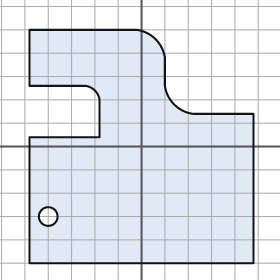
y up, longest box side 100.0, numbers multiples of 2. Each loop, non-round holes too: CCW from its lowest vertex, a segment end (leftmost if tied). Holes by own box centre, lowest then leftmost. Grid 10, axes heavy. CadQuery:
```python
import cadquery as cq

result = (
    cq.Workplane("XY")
    .moveTo(-48.0, -50.0)
    .lineTo(48.0, -50.0)
    .lineTo(48.0, 14.0)
    .lineTo(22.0, 14.0)
    .threePointArc((14.0, 18.0), (10.0, 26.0))
    .lineTo(10.0, 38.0)
    .threePointArc((6.0, 46.0), (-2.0, 50.0))
    .lineTo(-48.0, 50.0)
    .lineTo(-48.0, 26.0)
    .lineTo(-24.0, 26.0)
    .threePointArc((-20.0, 24.0), (-18.0, 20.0))
    .lineTo(-18.0, 4.0)
    .lineTo(-48.0, 4.0)
    .close()
    .moveTo(-40.0, -30.0)
    .circle(4.0)
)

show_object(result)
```